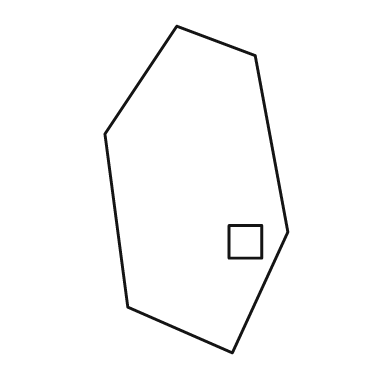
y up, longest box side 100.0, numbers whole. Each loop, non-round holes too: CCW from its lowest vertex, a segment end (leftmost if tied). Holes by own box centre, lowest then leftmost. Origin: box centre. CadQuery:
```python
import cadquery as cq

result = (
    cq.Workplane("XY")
    .moveTo(11.0, -50.0)
    .lineTo(28.0, -13.0)
    .lineTo(18.0, 41.0)
    .lineTo(-6.0, 50.0)
    .lineTo(-28.0, 17.0)
    .lineTo(-21.0, -36.0)
    .close()
    .moveTo(10.0, -21.0)
    .lineTo(20.0, -21.0)
    .lineTo(20.0, -11.0)
    .lineTo(10.0, -11.0)
    .close()
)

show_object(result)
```